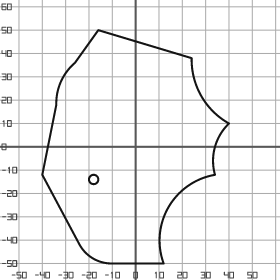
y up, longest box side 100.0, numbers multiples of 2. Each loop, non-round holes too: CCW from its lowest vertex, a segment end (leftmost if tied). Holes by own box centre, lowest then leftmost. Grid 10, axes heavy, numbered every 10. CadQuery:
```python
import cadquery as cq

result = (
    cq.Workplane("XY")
    .moveTo(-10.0, -50.0)
    .lineTo(12.0, -50.0)
    .threePointArc((14.0, -26.0), (34.0, -12.0))
    .threePointArc((34.0, 0.0), (40.0, 10.0))
    .threePointArc((28.0, 22.0), (24.0, 38.0))
    .lineTo(-16.0, 50.0)
    .lineTo(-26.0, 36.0)
    .threePointArc((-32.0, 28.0), (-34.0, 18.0))
    .lineTo(-40.0, -12.0)
    .lineTo(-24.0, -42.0)
    .threePointArc((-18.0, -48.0), (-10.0, -50.0))
    .close()
    .moveTo(-18.0, -14.0)
    .circle(2.0)
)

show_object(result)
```